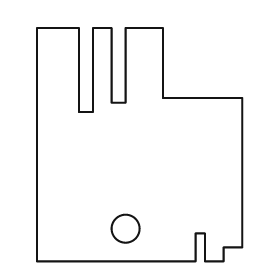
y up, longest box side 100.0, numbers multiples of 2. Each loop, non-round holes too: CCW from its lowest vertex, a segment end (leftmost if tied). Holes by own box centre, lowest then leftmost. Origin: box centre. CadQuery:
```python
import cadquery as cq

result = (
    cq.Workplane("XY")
    .moveTo(-44.0, -50.0)
    .lineTo(24.0, -50.0)
    .lineTo(24.0, -38.0)
    .lineTo(28.0, -38.0)
    .lineTo(28.0, -50.0)
    .lineTo(36.0, -50.0)
    .lineTo(36.0, -44.0)
    .lineTo(44.0, -44.0)
    .lineTo(44.0, 20.0)
    .lineTo(10.0, 20.0)
    .lineTo(10.0, 50.0)
    .lineTo(-6.0, 50.0)
    .lineTo(-6.0, 18.0)
    .lineTo(-12.0, 18.0)
    .lineTo(-12.0, 50.0)
    .lineTo(-20.0, 50.0)
    .lineTo(-20.0, 14.0)
    .lineTo(-26.0, 14.0)
    .lineTo(-26.0, 50.0)
    .lineTo(-44.0, 50.0)
    .close()
    .moveTo(-6.0, -36.0)
    .circle(6.0)
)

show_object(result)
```